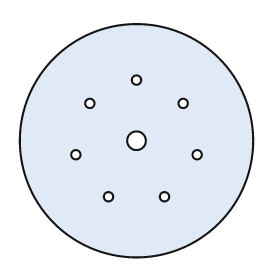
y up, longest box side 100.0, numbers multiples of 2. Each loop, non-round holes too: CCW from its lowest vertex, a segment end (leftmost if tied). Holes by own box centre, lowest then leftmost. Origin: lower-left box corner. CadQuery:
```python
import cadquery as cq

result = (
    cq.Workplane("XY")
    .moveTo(50.0, 50.0)
    .circle(50.0)
    .moveTo(38.0, 26.0)
    .circle(2.0)
    .moveTo(62.0, 26.0)
    .circle(2.0)
    .moveTo(24.0, 44.0)
    .circle(2.0)
    .moveTo(76.0, 44.0)
    .circle(2.0)
    .moveTo(50.0, 50.0)
    .circle(4.0)
    .moveTo(30.0, 66.0)
    .circle(2.0)
    .moveTo(70.0, 66.0)
    .circle(2.0)
    .moveTo(50.0, 76.0)
    .circle(2.0)
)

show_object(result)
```